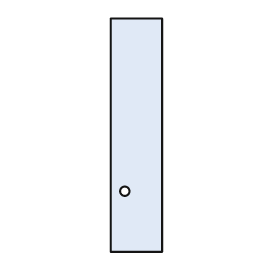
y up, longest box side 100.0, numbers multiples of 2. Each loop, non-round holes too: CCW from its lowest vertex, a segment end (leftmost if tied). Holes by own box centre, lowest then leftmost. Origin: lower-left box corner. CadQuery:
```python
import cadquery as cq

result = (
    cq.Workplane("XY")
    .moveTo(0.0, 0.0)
    .lineTo(22.0, 0.0)
    .lineTo(22.0, 100.0)
    .lineTo(0.0, 100.0)
    .close()
    .moveTo(6.0, 26.0)
    .circle(2.0)
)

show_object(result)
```